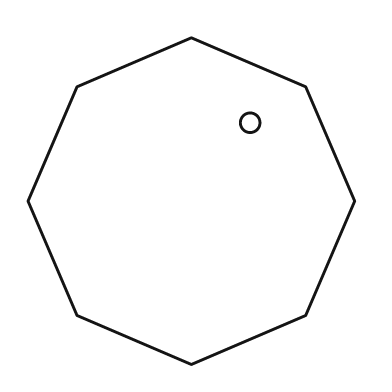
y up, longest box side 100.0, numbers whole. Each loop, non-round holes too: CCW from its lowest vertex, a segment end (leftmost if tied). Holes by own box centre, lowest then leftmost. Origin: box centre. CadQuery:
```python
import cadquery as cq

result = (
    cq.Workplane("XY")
    .moveTo(0.0, -50.0)
    .lineTo(35.0, -35.0)
    .lineTo(50.0, 0.0)
    .lineTo(35.0, 35.0)
    .lineTo(0.0, 50.0)
    .lineTo(-35.0, 35.0)
    .lineTo(-50.0, 0.0)
    .lineTo(-35.0, -35.0)
    .close()
    .moveTo(18.0, 24.0)
    .circle(3.0)
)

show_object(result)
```